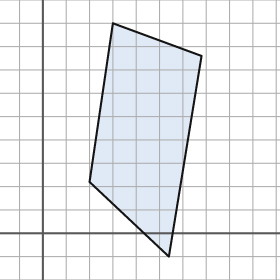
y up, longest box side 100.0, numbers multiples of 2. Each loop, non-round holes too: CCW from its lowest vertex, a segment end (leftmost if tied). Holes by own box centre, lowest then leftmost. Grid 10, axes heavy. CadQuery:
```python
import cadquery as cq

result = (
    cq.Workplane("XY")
    .moveTo(54.0, -10.0)
    .lineTo(68.0, 76.0)
    .lineTo(30.0, 90.0)
    .lineTo(20.0, 22.0)
    .close()
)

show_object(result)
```